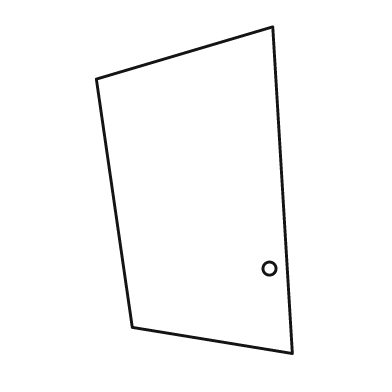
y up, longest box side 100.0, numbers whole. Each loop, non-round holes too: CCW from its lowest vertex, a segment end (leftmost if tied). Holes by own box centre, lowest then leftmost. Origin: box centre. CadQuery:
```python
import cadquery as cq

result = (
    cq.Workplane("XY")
    .moveTo(30.0, -50.0)
    .lineTo(24.0, 50.0)
    .lineTo(-30.0, 34.0)
    .lineTo(-19.0, -42.0)
    .close()
    .moveTo(23.0, -24.0)
    .circle(2.0)
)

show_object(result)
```